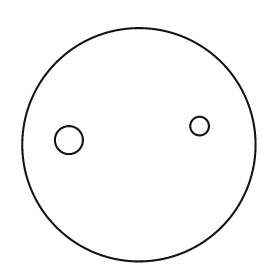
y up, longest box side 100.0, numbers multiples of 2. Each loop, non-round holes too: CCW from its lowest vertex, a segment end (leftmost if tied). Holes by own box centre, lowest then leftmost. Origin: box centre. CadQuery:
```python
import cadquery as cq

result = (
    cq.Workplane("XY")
    .moveTo(0.0, 0.0)
    .circle(50.0)
    .moveTo(-30.0, 2.0)
    .circle(6.0)
    .moveTo(26.0, 8.0)
    .circle(4.0)
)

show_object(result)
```